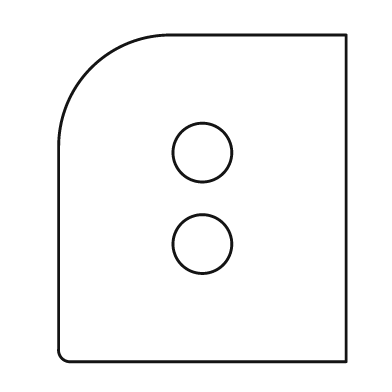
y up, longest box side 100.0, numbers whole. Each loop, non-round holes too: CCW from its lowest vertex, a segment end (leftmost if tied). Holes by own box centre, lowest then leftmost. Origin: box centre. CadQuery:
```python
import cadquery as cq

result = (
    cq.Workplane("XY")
    .moveTo(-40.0, -50.0)
    .lineTo(44.0, -50.0)
    .lineTo(44.0, 50.0)
    .lineTo(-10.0, 50.0)
    .threePointArc((-34.0, 40.0), (-44.0, 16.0))
    .lineTo(-44.0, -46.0)
    .threePointArc((-43.0, -49.0), (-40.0, -50.0))
    .close()
    .moveTo(0.0, -14.0)
    .circle(9.0)
    .moveTo(0.0, 14.0)
    .circle(9.0)
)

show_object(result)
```